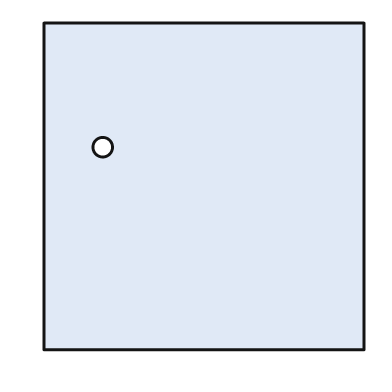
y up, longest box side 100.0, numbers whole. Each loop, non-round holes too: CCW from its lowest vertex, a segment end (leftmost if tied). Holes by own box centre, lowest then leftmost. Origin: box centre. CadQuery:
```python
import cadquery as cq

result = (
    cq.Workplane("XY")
    .moveTo(-49.0, -50.0)
    .lineTo(49.0, -50.0)
    .lineTo(49.0, 50.0)
    .lineTo(-49.0, 50.0)
    .close()
    .moveTo(-31.0, 12.0)
    .circle(3.0)
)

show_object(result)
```